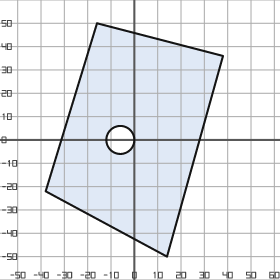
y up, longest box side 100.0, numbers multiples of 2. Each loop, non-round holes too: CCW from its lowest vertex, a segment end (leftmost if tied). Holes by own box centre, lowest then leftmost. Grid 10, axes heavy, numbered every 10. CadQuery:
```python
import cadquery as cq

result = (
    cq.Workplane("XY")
    .moveTo(14.0, -50.0)
    .lineTo(38.0, 36.0)
    .lineTo(-16.0, 50.0)
    .lineTo(-38.0, -22.0)
    .close()
    .moveTo(-6.0, 0.0)
    .circle(6.0)
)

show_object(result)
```